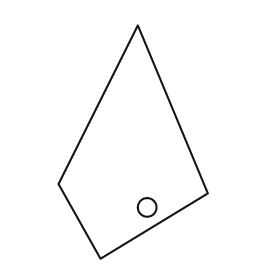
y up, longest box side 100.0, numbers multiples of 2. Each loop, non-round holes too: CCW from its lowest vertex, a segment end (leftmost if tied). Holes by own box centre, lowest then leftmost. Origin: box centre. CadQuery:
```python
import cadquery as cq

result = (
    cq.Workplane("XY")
    .moveTo(-14.0, -50.0)
    .lineTo(32.0, -22.0)
    .lineTo(2.0, 50.0)
    .lineTo(-32.0, -18.0)
    .close()
    .moveTo(6.0, -28.0)
    .circle(4.0)
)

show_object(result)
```